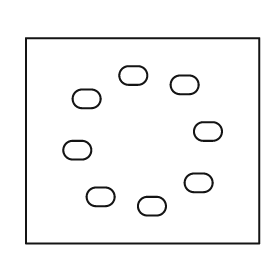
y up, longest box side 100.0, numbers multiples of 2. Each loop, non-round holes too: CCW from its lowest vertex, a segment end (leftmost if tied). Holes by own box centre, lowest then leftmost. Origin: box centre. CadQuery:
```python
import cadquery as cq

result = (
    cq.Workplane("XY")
    .moveTo(-50.0, -44.0)
    .lineTo(50.0, -44.0)
    .lineTo(50.0, 44.0)
    .lineTo(-50.0, 44.0)
    .close()
    .moveTo(2.0, -32.0)
    .lineTo(6.0, -32.0)
    .threePointArc((10.0, -28.0), (6.0, -24.0))
    .lineTo(2.0, -24.0)
    .threePointArc((-2.0, -28.0), (2.0, -32.0))
    .close()
    .moveTo(-20.0, -28.0)
    .lineTo(-16.0, -28.0)
    .threePointArc((-12.0, -24.0), (-16.0, -20.0))
    .lineTo(-20.0, -20.0)
    .threePointArc((-24.0, -24.0), (-20.0, -28.0))
    .close()
    .moveTo(22.0, -22.0)
    .lineTo(26.0, -22.0)
    .threePointArc((30.0, -18.0), (26.0, -14.0))
    .lineTo(22.0, -14.0)
    .threePointArc((18.0, -18.0), (22.0, -22.0))
    .close()
    .moveTo(-30.0, -8.0)
    .lineTo(-26.0, -8.0)
    .threePointArc((-22.0, -4.0), (-26.0, 0.0))
    .lineTo(-30.0, 0.0)
    .threePointArc((-34.0, -4.0), (-30.0, -8.0))
    .close()
    .moveTo(26.0, 0.0)
    .lineTo(30.0, 0.0)
    .threePointArc((34.0, 4.0), (30.0, 8.0))
    .lineTo(26.0, 8.0)
    .threePointArc((22.0, 4.0), (26.0, 0.0))
    .close()
    .moveTo(-26.0, 14.0)
    .lineTo(-22.0, 14.0)
    .threePointArc((-18.0, 18.0), (-22.0, 22.0))
    .lineTo(-26.0, 22.0)
    .threePointArc((-30.0, 18.0), (-26.0, 14.0))
    .close()
    .moveTo(16.0, 20.0)
    .lineTo(20.0, 20.0)
    .threePointArc((24.0, 24.0), (20.0, 28.0))
    .lineTo(16.0, 28.0)
    .threePointArc((12.0, 24.0), (16.0, 20.0))
    .close()
    .moveTo(-6.0, 24.0)
    .lineTo(-2.0, 24.0)
    .threePointArc((2.0, 28.0), (-2.0, 32.0))
    .lineTo(-6.0, 32.0)
    .threePointArc((-10.0, 28.0), (-6.0, 24.0))
    .close()
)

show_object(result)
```